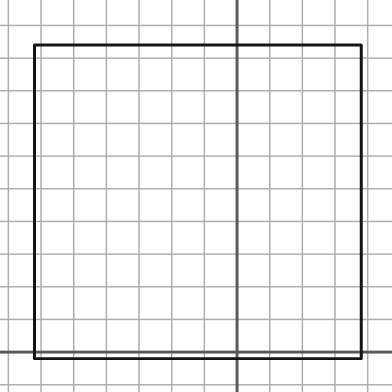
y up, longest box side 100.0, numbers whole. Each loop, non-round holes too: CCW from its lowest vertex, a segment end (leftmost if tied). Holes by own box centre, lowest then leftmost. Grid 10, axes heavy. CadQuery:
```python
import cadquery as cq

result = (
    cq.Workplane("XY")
    .moveTo(-62.0, -2.0)
    .lineTo(38.0, -2.0)
    .lineTo(38.0, 94.0)
    .lineTo(-62.0, 94.0)
    .close()
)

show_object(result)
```